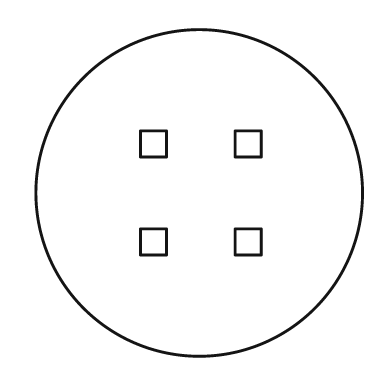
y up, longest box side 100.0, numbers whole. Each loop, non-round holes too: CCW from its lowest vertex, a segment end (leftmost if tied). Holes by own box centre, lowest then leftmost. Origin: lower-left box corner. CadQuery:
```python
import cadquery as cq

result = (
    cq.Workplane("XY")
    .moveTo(50.0, 50.0)
    .circle(50.0)
    .moveTo(32.0, 31.0)
    .lineTo(40.0, 31.0)
    .lineTo(40.0, 39.0)
    .lineTo(32.0, 39.0)
    .close()
    .moveTo(61.0, 31.0)
    .lineTo(69.0, 31.0)
    .lineTo(69.0, 39.0)
    .lineTo(61.0, 39.0)
    .close()
    .moveTo(32.0, 61.0)
    .lineTo(40.0, 61.0)
    .lineTo(40.0, 69.0)
    .lineTo(32.0, 69.0)
    .close()
    .moveTo(61.0, 61.0)
    .lineTo(69.0, 61.0)
    .lineTo(69.0, 69.0)
    .lineTo(61.0, 69.0)
    .close()
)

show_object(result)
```